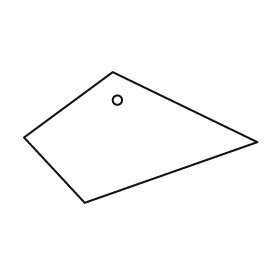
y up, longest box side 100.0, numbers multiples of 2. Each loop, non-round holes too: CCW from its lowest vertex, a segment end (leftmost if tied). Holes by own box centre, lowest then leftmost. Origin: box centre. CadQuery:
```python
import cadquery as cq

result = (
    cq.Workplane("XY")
    .moveTo(-24.0, -28.0)
    .lineTo(50.0, -2.0)
    .lineTo(-12.0, 28.0)
    .lineTo(-50.0, 0.0)
    .close()
    .moveTo(-10.0, 16.0)
    .circle(2.0)
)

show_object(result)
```